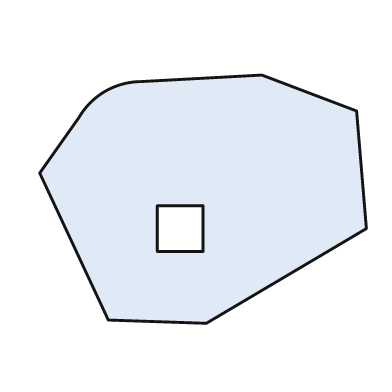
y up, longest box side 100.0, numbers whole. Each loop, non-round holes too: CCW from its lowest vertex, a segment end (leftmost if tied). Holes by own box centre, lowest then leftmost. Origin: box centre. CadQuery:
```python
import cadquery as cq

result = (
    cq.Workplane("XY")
    .moveTo(1.0, -38.0)
    .lineTo(50.0, -9.0)
    .lineTo(47.0, 27.0)
    .lineTo(18.0, 38.0)
    .lineTo(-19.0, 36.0)
    .threePointArc((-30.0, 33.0), (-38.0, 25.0))
    .lineTo(-50.0, 8.0)
    .lineTo(-29.0, -37.0)
    .close()
    .moveTo(-14.0, -16.0)
    .lineTo(0.0, -16.0)
    .lineTo(0.0, -2.0)
    .lineTo(-14.0, -2.0)
    .close()
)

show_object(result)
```